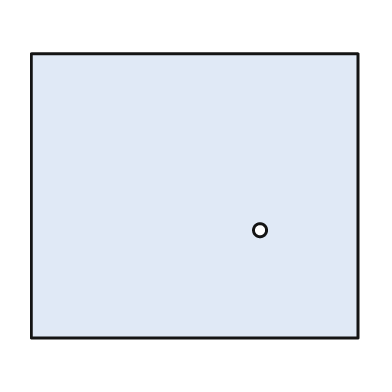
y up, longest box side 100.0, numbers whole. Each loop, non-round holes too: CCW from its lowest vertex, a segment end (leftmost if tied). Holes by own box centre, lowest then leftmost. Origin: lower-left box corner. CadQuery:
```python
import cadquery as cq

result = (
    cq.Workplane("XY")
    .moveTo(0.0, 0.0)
    .lineTo(100.0, 0.0)
    .lineTo(100.0, 87.0)
    .lineTo(0.0, 87.0)
    .close()
    .moveTo(70.0, 33.0)
    .circle(2.0)
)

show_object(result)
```